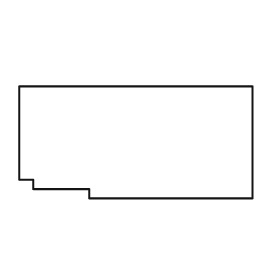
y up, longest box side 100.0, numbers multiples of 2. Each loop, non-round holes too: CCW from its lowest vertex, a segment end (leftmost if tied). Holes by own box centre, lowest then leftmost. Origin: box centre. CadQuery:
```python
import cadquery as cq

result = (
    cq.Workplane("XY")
    .moveTo(-20.0, -24.0)
    .lineTo(50.0, -24.0)
    .lineTo(50.0, 24.0)
    .lineTo(-50.0, 24.0)
    .lineTo(-50.0, -16.0)
    .lineTo(-44.0, -16.0)
    .lineTo(-44.0, -20.0)
    .lineTo(-20.0, -20.0)
    .close()
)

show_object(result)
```